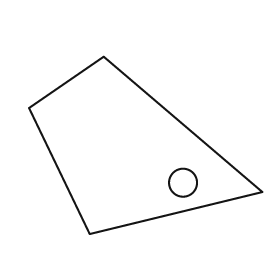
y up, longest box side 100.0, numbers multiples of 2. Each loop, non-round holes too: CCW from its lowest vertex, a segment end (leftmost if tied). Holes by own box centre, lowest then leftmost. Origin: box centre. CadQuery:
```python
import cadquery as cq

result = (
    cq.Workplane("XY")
    .moveTo(-24.0, -38.0)
    .lineTo(50.0, -20.0)
    .lineTo(-18.0, 38.0)
    .lineTo(-50.0, 16.0)
    .close()
    .moveTo(16.0, -16.0)
    .circle(6.0)
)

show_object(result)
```